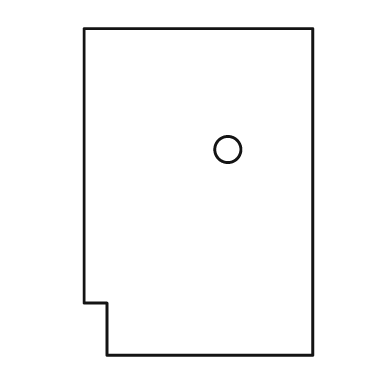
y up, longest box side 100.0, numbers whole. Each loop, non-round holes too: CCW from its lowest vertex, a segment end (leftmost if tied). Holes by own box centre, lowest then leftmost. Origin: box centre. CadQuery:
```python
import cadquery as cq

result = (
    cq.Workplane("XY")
    .moveTo(-28.0, -50.0)
    .lineTo(35.0, -50.0)
    .lineTo(35.0, 50.0)
    .lineTo(-35.0, 50.0)
    .lineTo(-35.0, -34.0)
    .lineTo(-28.0, -34.0)
    .close()
    .moveTo(9.0, 13.0)
    .circle(4.0)
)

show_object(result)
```